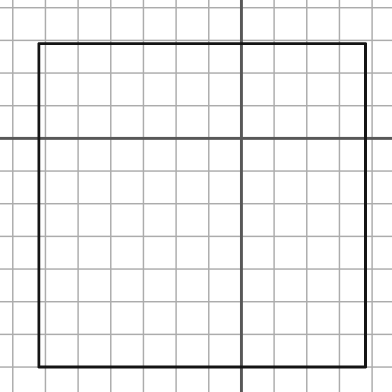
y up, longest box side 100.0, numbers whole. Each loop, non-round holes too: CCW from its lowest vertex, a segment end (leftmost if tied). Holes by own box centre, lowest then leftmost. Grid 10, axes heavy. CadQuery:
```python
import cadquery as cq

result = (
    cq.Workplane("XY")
    .moveTo(-62.0, -70.0)
    .lineTo(38.0, -70.0)
    .lineTo(38.0, 29.0)
    .lineTo(-62.0, 29.0)
    .close()
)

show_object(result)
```